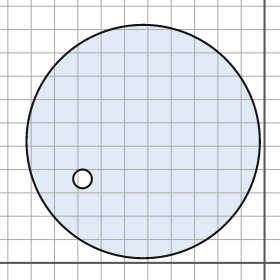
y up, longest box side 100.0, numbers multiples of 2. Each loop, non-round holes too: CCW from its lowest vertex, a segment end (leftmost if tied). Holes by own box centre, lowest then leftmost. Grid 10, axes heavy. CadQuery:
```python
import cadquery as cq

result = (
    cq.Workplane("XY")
    .moveTo(-52.0, 52.0)
    .circle(50.0)
    .moveTo(-78.0, 36.0)
    .circle(4.0)
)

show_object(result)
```